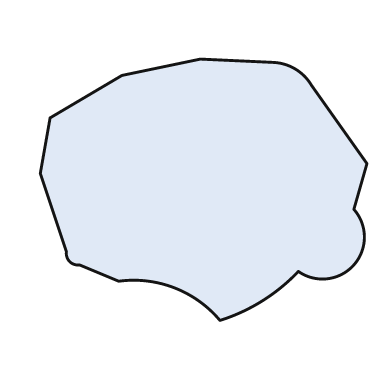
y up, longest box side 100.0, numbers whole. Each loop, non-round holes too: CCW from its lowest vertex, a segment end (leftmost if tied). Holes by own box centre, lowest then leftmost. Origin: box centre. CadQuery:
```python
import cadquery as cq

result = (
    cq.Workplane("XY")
    .moveTo(5.0, -40.0)
    .threePointArc((18.0, -34.0), (29.0, -25.0))
    .threePointArc((46.0, -23.0), (46.0, -6.0))
    .lineTo(50.0, 8.0)
    .lineTo(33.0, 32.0)
    .threePointArc((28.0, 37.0), (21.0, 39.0))
    .lineTo(-1.0, 40.0)
    .lineTo(-25.0, 35.0)
    .lineTo(-47.0, 22.0)
    .lineTo(-50.0, 5.0)
    .lineTo(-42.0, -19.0)
    .threePointArc((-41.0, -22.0), (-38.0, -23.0))
    .lineTo(-26.0, -28.0)
    .threePointArc((-9.0, -30.0), (5.0, -40.0))
    .close()
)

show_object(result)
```